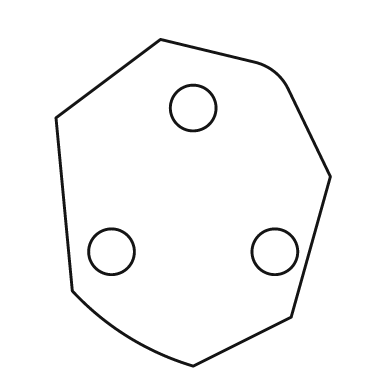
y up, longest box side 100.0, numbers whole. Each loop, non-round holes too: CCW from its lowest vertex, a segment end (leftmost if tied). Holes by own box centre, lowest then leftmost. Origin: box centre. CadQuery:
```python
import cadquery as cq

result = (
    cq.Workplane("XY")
    .moveTo(0.0, -50.0)
    .lineTo(30.0, -35.0)
    .lineTo(42.0, 8.0)
    .lineTo(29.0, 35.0)
    .threePointArc((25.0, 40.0), (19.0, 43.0))
    .lineTo(-10.0, 50.0)
    .lineTo(-42.0, 26.0)
    .lineTo(-37.0, -27.0)
    .threePointArc((-20.0, -41.0), (0.0, -50.0))
    .close()
    .moveTo(-25.0, -15.0)
    .circle(7.0)
    .moveTo(25.0, -15.0)
    .circle(7.0)
    .moveTo(0.0, 29.0)
    .circle(7.0)
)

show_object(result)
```